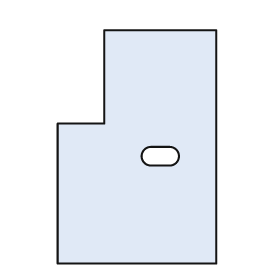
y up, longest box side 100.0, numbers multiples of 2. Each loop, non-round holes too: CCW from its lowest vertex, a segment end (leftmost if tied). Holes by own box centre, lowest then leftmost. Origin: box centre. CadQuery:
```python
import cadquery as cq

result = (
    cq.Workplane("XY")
    .moveTo(-34.0, -50.0)
    .lineTo(34.0, -50.0)
    .lineTo(34.0, 50.0)
    .lineTo(-14.0, 50.0)
    .lineTo(-14.0, 10.0)
    .lineTo(-34.0, 10.0)
    .close()
    .moveTo(6.0, -8.0)
    .lineTo(14.0, -8.0)
    .threePointArc((18.0, -4.0), (14.0, 0.0))
    .lineTo(6.0, 0.0)
    .threePointArc((2.0, -4.0), (6.0, -8.0))
    .close()
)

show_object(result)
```